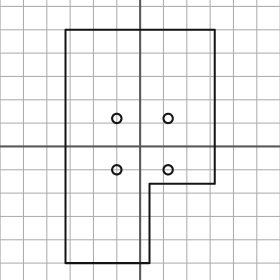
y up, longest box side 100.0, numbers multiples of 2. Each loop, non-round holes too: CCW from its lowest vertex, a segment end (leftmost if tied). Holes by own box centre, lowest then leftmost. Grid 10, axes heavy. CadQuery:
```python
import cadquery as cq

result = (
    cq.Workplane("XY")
    .moveTo(-32.0, -50.0)
    .lineTo(4.0, -50.0)
    .lineTo(4.0, -16.0)
    .lineTo(32.0, -16.0)
    .lineTo(32.0, 50.0)
    .lineTo(-32.0, 50.0)
    .close()
    .moveTo(-10.0, -10.0)
    .circle(2.0)
    .moveTo(12.0, -10.0)
    .circle(2.0)
    .moveTo(-10.0, 12.0)
    .circle(2.0)
    .moveTo(12.0, 12.0)
    .circle(2.0)
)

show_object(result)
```